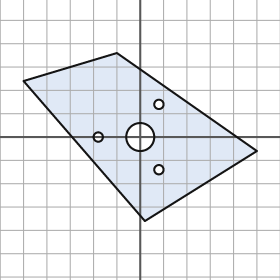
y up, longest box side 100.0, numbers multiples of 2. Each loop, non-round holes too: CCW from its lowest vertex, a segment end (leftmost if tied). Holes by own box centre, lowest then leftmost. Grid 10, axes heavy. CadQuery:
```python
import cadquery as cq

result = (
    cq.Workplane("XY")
    .moveTo(2.0, -36.0)
    .lineTo(50.0, -6.0)
    .lineTo(-10.0, 36.0)
    .lineTo(-50.0, 24.0)
    .close()
    .moveTo(8.0, -14.0)
    .circle(2.0)
    .moveTo(-18.0, 0.0)
    .circle(2.0)
    .moveTo(0.0, 0.0)
    .circle(6.0)
    .moveTo(8.0, 14.0)
    .circle(2.0)
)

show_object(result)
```